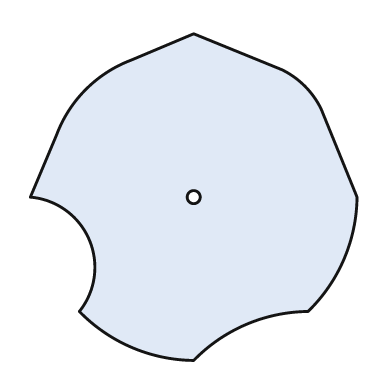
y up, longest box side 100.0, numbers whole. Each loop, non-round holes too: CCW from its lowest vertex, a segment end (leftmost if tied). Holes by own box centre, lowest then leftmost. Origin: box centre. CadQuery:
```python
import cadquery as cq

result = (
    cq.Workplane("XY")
    .moveTo(0.0, -50.0)
    .threePointArc((16.0, -39.0), (35.0, -35.0))
    .threePointArc((46.0, -19.0), (50.0, 0.0))
    .lineTo(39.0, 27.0)
    .threePointArc((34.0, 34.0), (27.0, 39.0))
    .lineTo(0.0, 50.0)
    .lineTo(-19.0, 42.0)
    .threePointArc((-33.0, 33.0), (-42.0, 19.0))
    .lineTo(-50.0, 0.0)
    .threePointArc((-32.0, -13.0), (-35.0, -35.0))
    .threePointArc((-19.0, -46.0), (0.0, -50.0))
    .close()
    .moveTo(0.0, 0.0)
    .circle(2.0)
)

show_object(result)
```